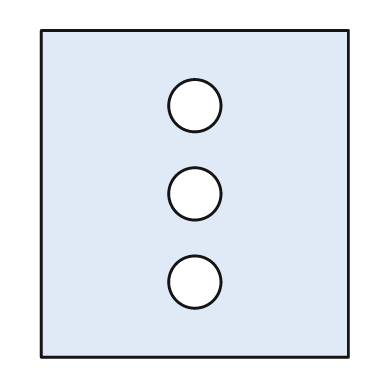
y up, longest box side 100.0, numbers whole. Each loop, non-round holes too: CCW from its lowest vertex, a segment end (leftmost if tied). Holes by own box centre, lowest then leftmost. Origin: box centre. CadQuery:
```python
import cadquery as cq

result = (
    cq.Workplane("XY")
    .moveTo(-47.0, -50.0)
    .lineTo(47.0, -50.0)
    .lineTo(47.0, 50.0)
    .lineTo(-47.0, 50.0)
    .close()
    .moveTo(0.0, -27.0)
    .circle(8.0)
    .moveTo(0.0, 0.0)
    .circle(8.0)
    .moveTo(0.0, 27.0)
    .circle(8.0)
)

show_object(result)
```